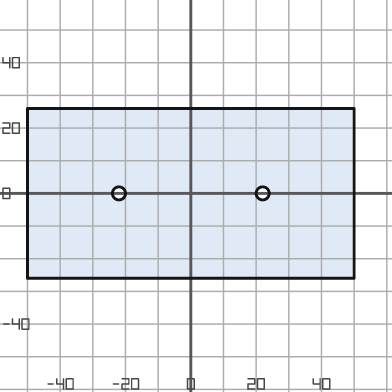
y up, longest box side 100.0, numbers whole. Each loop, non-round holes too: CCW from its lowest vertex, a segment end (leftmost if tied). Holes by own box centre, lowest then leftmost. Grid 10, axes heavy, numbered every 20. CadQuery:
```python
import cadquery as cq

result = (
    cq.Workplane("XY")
    .moveTo(-50.0, -26.0)
    .lineTo(50.0, -26.0)
    .lineTo(50.0, 26.0)
    .lineTo(-50.0, 26.0)
    .close()
    .moveTo(-22.0, 0.0)
    .circle(2.0)
    .moveTo(22.0, 0.0)
    .circle(2.0)
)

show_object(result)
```